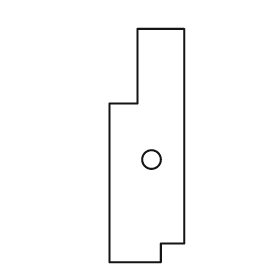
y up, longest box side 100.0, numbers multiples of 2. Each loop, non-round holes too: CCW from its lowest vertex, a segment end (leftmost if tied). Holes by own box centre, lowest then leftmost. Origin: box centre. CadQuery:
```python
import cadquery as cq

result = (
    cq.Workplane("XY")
    .moveTo(-16.0, -50.0)
    .lineTo(6.0, -50.0)
    .lineTo(6.0, -42.0)
    .lineTo(16.0, -42.0)
    .lineTo(16.0, 50.0)
    .lineTo(-4.0, 50.0)
    .lineTo(-4.0, 18.0)
    .lineTo(-16.0, 18.0)
    .close()
    .moveTo(2.0, -6.0)
    .circle(4.0)
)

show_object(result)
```